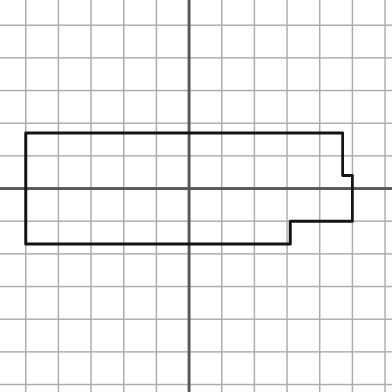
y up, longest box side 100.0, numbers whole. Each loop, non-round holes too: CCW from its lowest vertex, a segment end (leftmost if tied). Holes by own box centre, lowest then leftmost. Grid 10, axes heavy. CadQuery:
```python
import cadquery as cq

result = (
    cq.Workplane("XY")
    .moveTo(-50.0, -17.0)
    .lineTo(31.0, -17.0)
    .lineTo(31.0, -10.0)
    .lineTo(50.0, -10.0)
    .lineTo(50.0, 4.0)
    .lineTo(47.0, 4.0)
    .lineTo(47.0, 17.0)
    .lineTo(-50.0, 17.0)
    .close()
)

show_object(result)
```